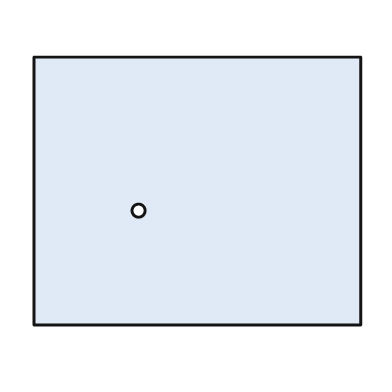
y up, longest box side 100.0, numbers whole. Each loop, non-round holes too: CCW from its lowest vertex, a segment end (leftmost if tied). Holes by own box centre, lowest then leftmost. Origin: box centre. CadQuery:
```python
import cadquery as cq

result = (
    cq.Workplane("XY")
    .moveTo(-50.0, -41.0)
    .lineTo(50.0, -41.0)
    .lineTo(50.0, 41.0)
    .lineTo(-50.0, 41.0)
    .close()
    .moveTo(-18.0, -6.0)
    .circle(2.0)
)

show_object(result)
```